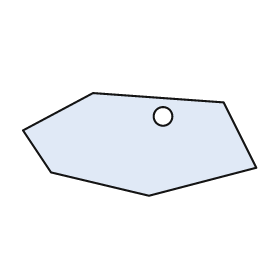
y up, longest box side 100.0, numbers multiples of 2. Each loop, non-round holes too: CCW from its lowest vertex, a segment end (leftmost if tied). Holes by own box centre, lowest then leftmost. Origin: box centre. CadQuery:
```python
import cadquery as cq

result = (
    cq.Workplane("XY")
    .moveTo(4.0, -22.0)
    .lineTo(50.0, -10.0)
    .lineTo(36.0, 18.0)
    .lineTo(-20.0, 22.0)
    .lineTo(-50.0, 6.0)
    .lineTo(-38.0, -12.0)
    .close()
    .moveTo(10.0, 12.0)
    .circle(4.0)
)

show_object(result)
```